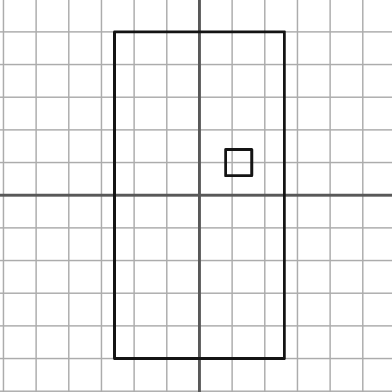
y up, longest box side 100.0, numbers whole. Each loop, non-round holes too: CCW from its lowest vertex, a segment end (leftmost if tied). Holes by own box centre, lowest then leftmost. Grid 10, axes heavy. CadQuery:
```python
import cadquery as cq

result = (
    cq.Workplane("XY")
    .moveTo(-26.0, -50.0)
    .lineTo(26.0, -50.0)
    .lineTo(26.0, 50.0)
    .lineTo(-26.0, 50.0)
    .close()
    .moveTo(8.0, 6.0)
    .lineTo(16.0, 6.0)
    .lineTo(16.0, 14.0)
    .lineTo(8.0, 14.0)
    .close()
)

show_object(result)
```